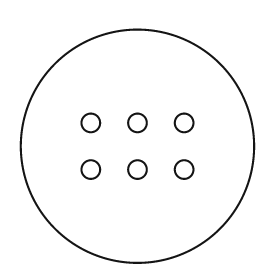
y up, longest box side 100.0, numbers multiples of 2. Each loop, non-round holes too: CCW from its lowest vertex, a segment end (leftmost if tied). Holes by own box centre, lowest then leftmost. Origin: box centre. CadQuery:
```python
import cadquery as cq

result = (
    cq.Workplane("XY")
    .moveTo(0.0, 0.0)
    .circle(50.0)
    .moveTo(-20.0, -10.0)
    .circle(4.0)
    .moveTo(0.0, -10.0)
    .circle(4.0)
    .moveTo(20.0, -10.0)
    .circle(4.0)
    .moveTo(-20.0, 10.0)
    .circle(4.0)
    .moveTo(0.0, 10.0)
    .circle(4.0)
    .moveTo(20.0, 10.0)
    .circle(4.0)
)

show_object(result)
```